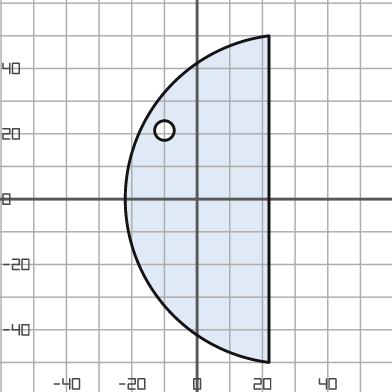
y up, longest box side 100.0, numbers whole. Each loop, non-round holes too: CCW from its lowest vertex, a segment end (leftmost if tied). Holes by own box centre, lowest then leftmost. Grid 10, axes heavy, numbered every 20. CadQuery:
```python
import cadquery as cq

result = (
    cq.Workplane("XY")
    .moveTo(22.0, -50.0)
    .lineTo(22.0, 50.0)
    .threePointArc((-22.0, 0.0), (22.0, -50.0))
    .close()
    .moveTo(-10.0, 21.0)
    .circle(3.0)
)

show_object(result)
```